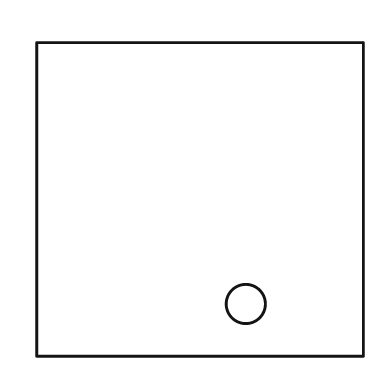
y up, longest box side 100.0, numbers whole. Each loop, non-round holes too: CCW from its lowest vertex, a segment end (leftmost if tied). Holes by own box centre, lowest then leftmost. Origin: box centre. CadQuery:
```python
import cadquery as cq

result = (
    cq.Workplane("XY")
    .moveTo(-50.0, -48.0)
    .lineTo(50.0, -48.0)
    .lineTo(50.0, 48.0)
    .lineTo(-50.0, 48.0)
    .close()
    .moveTo(14.0, -32.0)
    .circle(6.0)
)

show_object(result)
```